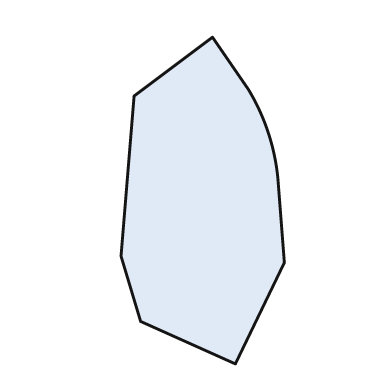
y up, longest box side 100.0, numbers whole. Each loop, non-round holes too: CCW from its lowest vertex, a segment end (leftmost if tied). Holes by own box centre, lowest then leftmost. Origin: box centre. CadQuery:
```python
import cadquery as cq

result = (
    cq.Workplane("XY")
    .moveTo(10.0, -50.0)
    .lineTo(25.0, -19.0)
    .lineTo(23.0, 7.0)
    .threePointArc((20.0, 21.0), (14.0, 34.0))
    .lineTo(3.0, 50.0)
    .lineTo(-21.0, 32.0)
    .lineTo(-25.0, -17.0)
    .lineTo(-19.0, -37.0)
    .close()
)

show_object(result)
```